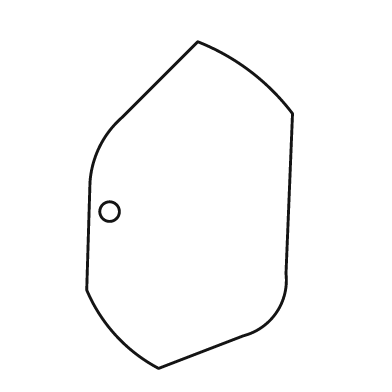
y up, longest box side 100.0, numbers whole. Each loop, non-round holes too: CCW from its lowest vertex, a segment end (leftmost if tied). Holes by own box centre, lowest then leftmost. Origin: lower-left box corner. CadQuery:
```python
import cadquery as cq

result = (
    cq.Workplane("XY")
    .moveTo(22.0, 0.0)
    .lineTo(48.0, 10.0)
    .threePointArc((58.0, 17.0), (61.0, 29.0))
    .lineTo(63.0, 78.0)
    .threePointArc((50.0, 91.0), (34.0, 100.0))
    .lineTo(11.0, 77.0)
    .threePointArc((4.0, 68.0), (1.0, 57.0))
    .lineTo(0.0, 24.0)
    .threePointArc((9.0, 10.0), (22.0, 0.0))
    .close()
    .moveTo(7.0, 48.0)
    .circle(3.0)
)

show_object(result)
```